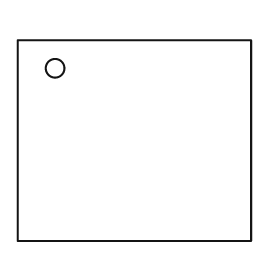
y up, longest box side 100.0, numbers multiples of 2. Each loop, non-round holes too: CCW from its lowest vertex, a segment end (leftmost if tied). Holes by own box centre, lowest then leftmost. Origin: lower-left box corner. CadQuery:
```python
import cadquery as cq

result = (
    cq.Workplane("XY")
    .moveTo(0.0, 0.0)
    .lineTo(100.0, 0.0)
    .lineTo(100.0, 86.0)
    .lineTo(0.0, 86.0)
    .close()
    .moveTo(16.0, 74.0)
    .circle(4.0)
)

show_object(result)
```